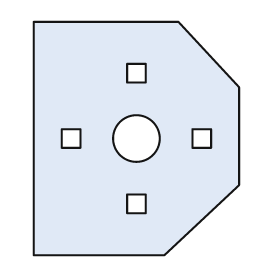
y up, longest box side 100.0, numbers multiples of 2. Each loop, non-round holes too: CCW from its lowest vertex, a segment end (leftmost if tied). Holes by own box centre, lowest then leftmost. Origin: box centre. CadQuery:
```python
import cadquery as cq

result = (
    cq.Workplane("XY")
    .moveTo(-44.0, -50.0)
    .lineTo(12.0, -50.0)
    .lineTo(44.0, -20.0)
    .lineTo(44.0, 22.0)
    .lineTo(18.0, 50.0)
    .lineTo(-44.0, 50.0)
    .close()
    .moveTo(-4.0, -32.0)
    .lineTo(4.0, -32.0)
    .lineTo(4.0, -24.0)
    .lineTo(-4.0, -24.0)
    .close()
    .moveTo(-32.0, -4.0)
    .lineTo(-24.0, -4.0)
    .lineTo(-24.0, 4.0)
    .lineTo(-32.0, 4.0)
    .close()
    .moveTo(0.0, 0.0)
    .circle(10.0)
    .moveTo(24.0, -4.0)
    .lineTo(32.0, -4.0)
    .lineTo(32.0, 4.0)
    .lineTo(24.0, 4.0)
    .close()
    .moveTo(-4.0, 24.0)
    .lineTo(4.0, 24.0)
    .lineTo(4.0, 32.0)
    .lineTo(-4.0, 32.0)
    .close()
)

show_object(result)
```